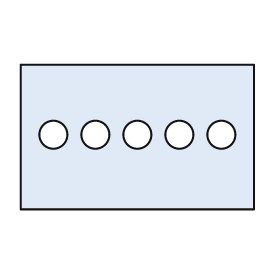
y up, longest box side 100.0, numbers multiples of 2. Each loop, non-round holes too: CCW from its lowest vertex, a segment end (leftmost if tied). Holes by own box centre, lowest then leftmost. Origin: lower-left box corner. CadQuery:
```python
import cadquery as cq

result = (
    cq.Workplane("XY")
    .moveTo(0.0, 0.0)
    .lineTo(100.0, 0.0)
    .lineTo(100.0, 62.0)
    .lineTo(0.0, 62.0)
    .close()
    .moveTo(14.0, 32.0)
    .circle(6.0)
    .moveTo(32.0, 32.0)
    .circle(6.0)
    .moveTo(50.0, 32.0)
    .circle(6.0)
    .moveTo(68.0, 32.0)
    .circle(6.0)
    .moveTo(86.0, 32.0)
    .circle(6.0)
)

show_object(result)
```